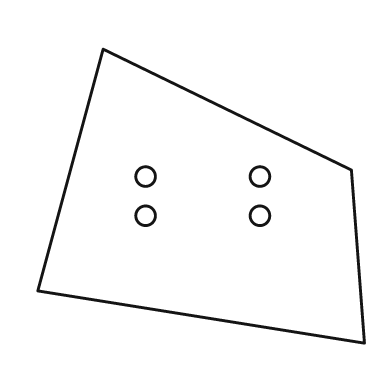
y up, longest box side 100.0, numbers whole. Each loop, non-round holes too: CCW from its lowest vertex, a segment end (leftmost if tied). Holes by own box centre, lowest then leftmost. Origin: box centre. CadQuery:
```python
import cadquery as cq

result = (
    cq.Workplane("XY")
    .moveTo(50.0, -45.0)
    .lineTo(46.0, 8.0)
    .lineTo(-30.0, 45.0)
    .lineTo(-50.0, -29.0)
    .close()
    .moveTo(-17.0, -6.0)
    .circle(3.0)
    .moveTo(18.0, -6.0)
    .circle(3.0)
    .moveTo(-17.0, 6.0)
    .circle(3.0)
    .moveTo(18.0, 6.0)
    .circle(3.0)
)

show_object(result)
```